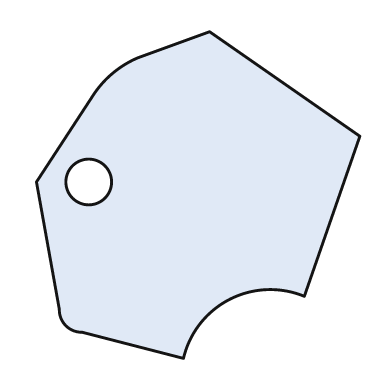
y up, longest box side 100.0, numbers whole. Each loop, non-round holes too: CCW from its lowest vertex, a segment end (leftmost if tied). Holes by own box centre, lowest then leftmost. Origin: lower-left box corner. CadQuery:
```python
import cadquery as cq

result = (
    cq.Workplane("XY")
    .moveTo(45.0, 0.0)
    .threePointArc((59.0, 18.0), (82.0, 19.0))
    .lineTo(99.0, 68.0)
    .lineTo(53.0, 100.0)
    .lineTo(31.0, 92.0)
    .threePointArc((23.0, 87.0), (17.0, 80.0))
    .lineTo(0.0, 54.0)
    .lineTo(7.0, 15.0)
    .threePointArc((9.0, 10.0), (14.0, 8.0))
    .close()
    .moveTo(16.0, 54.0)
    .circle(7.0)
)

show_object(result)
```